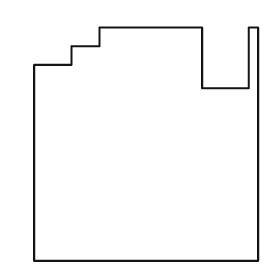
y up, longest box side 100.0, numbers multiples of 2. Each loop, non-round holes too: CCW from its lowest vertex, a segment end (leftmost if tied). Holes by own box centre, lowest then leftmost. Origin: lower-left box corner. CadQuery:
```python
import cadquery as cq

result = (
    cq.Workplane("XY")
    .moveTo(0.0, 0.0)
    .lineTo(96.0, 0.0)
    .lineTo(96.0, 100.0)
    .lineTo(92.0, 100.0)
    .lineTo(92.0, 74.0)
    .lineTo(72.0, 74.0)
    .lineTo(72.0, 100.0)
    .lineTo(28.0, 100.0)
    .lineTo(28.0, 92.0)
    .lineTo(16.0, 92.0)
    .lineTo(16.0, 84.0)
    .lineTo(0.0, 84.0)
    .close()
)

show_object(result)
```